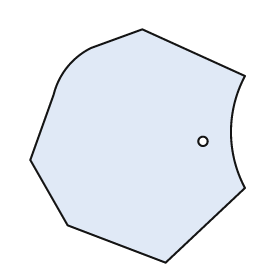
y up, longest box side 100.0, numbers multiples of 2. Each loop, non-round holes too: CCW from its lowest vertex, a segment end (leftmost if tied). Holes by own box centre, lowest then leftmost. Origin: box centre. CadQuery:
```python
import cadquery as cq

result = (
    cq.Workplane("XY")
    .moveTo(12.0, -50.0)
    .lineTo(46.0, -18.0)
    .threePointArc((40.0, 6.0), (46.0, 30.0))
    .lineTo(2.0, 50.0)
    .lineTo(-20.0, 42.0)
    .threePointArc((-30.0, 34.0), (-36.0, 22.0))
    .lineTo(-46.0, -6.0)
    .lineTo(-30.0, -34.0)
    .close()
    .moveTo(28.0, 2.0)
    .circle(2.0)
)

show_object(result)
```